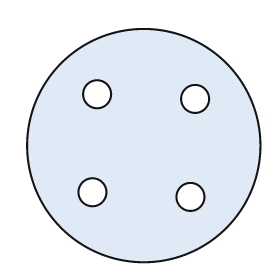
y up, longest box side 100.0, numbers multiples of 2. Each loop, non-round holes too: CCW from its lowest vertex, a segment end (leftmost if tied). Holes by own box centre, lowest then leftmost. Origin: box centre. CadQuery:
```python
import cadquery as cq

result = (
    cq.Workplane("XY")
    .moveTo(0.0, 0.0)
    .circle(50.0)
    .moveTo(20.0, -22.0)
    .circle(6.0)
    .moveTo(-22.0, -20.0)
    .circle(6.0)
    .moveTo(22.0, 20.0)
    .circle(6.0)
    .moveTo(-20.0, 22.0)
    .circle(6.0)
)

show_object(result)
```